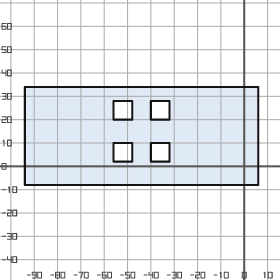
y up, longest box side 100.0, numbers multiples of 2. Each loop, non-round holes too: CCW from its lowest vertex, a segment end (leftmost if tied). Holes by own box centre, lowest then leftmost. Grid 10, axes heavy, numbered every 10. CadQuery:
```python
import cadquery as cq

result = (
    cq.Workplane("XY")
    .moveTo(-94.0, -8.0)
    .lineTo(6.0, -8.0)
    .lineTo(6.0, 34.0)
    .lineTo(-94.0, 34.0)
    .close()
    .moveTo(-56.0, 2.0)
    .lineTo(-48.0, 2.0)
    .lineTo(-48.0, 10.0)
    .lineTo(-56.0, 10.0)
    .close()
    .moveTo(-40.0, 2.0)
    .lineTo(-32.0, 2.0)
    .lineTo(-32.0, 10.0)
    .lineTo(-40.0, 10.0)
    .close()
    .moveTo(-56.0, 20.0)
    .lineTo(-48.0, 20.0)
    .lineTo(-48.0, 28.0)
    .lineTo(-56.0, 28.0)
    .close()
    .moveTo(-40.0, 20.0)
    .lineTo(-32.0, 20.0)
    .lineTo(-32.0, 28.0)
    .lineTo(-40.0, 28.0)
    .close()
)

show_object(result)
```